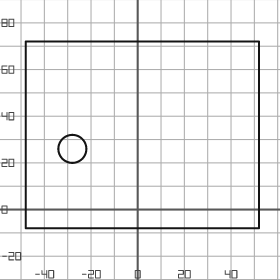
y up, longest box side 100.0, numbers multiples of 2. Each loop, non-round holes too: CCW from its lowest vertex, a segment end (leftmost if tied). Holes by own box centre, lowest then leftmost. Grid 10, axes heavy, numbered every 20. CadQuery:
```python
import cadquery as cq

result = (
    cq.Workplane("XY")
    .moveTo(-48.0, -8.0)
    .lineTo(52.0, -8.0)
    .lineTo(52.0, 72.0)
    .lineTo(-48.0, 72.0)
    .close()
    .moveTo(-28.0, 26.0)
    .circle(6.0)
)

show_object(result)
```